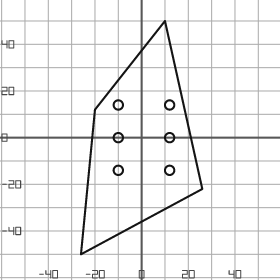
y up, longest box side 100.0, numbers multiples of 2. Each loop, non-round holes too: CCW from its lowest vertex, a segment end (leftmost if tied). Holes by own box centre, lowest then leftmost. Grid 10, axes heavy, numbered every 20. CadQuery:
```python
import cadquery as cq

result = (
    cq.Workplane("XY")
    .moveTo(-26.0, -50.0)
    .lineTo(26.0, -22.0)
    .lineTo(10.0, 50.0)
    .lineTo(-20.0, 12.0)
    .close()
    .moveTo(-10.0, -14.0)
    .circle(2.0)
    .moveTo(12.0, -14.0)
    .circle(2.0)
    .moveTo(-10.0, 0.0)
    .circle(2.0)
    .moveTo(12.0, 0.0)
    .circle(2.0)
    .moveTo(-10.0, 14.0)
    .circle(2.0)
    .moveTo(12.0, 14.0)
    .circle(2.0)
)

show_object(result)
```